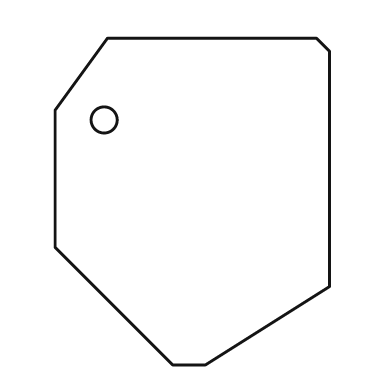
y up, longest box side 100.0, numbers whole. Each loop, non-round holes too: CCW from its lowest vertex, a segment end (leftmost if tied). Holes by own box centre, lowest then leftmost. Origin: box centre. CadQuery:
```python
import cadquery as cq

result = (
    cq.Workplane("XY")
    .moveTo(-6.0, -50.0)
    .lineTo(4.0, -50.0)
    .lineTo(42.0, -26.0)
    .lineTo(42.0, 46.0)
    .lineTo(38.0, 50.0)
    .lineTo(-26.0, 50.0)
    .lineTo(-42.0, 28.0)
    .lineTo(-42.0, -14.0)
    .close()
    .moveTo(-27.0, 25.0)
    .circle(4.0)
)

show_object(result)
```